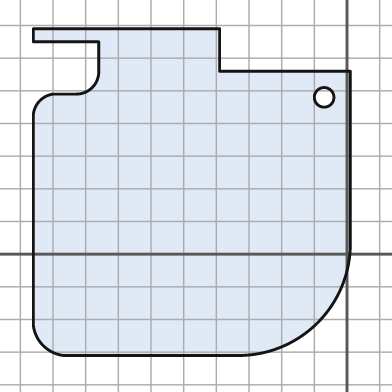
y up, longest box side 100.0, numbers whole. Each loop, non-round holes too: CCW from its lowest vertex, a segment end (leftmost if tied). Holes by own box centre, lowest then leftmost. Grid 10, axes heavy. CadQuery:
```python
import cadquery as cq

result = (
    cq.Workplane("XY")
    .moveTo(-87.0, -31.0)
    .lineTo(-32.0, -31.0)
    .threePointArc((-9.0, -21.0), (1.0, 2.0))
    .lineTo(1.0, 56.0)
    .lineTo(-39.0, 56.0)
    .lineTo(-39.0, 69.0)
    .lineTo(-96.0, 69.0)
    .lineTo(-96.0, 65.0)
    .lineTo(-76.0, 65.0)
    .lineTo(-76.0, 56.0)
    .threePointArc((-78.0, 51.0), (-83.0, 49.0))
    .lineTo(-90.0, 49.0)
    .threePointArc((-94.0, 47.0), (-96.0, 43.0))
    .lineTo(-96.0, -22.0)
    .threePointArc((-93.0, -28.0), (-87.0, -31.0))
    .close()
    .moveTo(-7.0, 48.0)
    .circle(3.0)
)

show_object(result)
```